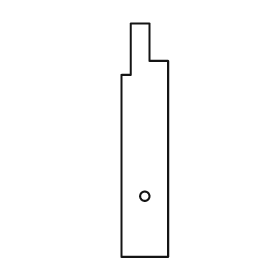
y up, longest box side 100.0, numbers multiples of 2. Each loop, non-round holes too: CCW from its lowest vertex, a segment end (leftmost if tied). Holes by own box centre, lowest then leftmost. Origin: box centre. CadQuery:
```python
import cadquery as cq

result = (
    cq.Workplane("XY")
    .moveTo(-10.0, -50.0)
    .lineTo(10.0, -50.0)
    .lineTo(10.0, 34.0)
    .lineTo(2.0, 34.0)
    .lineTo(2.0, 50.0)
    .lineTo(-6.0, 50.0)
    .lineTo(-6.0, 28.0)
    .lineTo(-10.0, 28.0)
    .close()
    .moveTo(0.0, -24.0)
    .circle(2.0)
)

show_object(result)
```